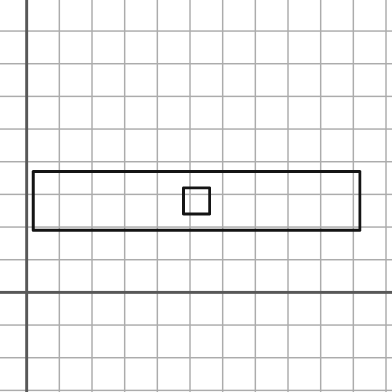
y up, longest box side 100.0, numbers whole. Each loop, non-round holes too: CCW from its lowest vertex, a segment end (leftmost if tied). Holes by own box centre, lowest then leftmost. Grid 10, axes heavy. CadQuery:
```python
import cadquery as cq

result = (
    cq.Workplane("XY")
    .moveTo(2.0, 19.0)
    .lineTo(102.0, 19.0)
    .lineTo(102.0, 37.0)
    .lineTo(2.0, 37.0)
    .close()
    .moveTo(48.0, 24.0)
    .lineTo(56.0, 24.0)
    .lineTo(56.0, 32.0)
    .lineTo(48.0, 32.0)
    .close()
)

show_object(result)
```